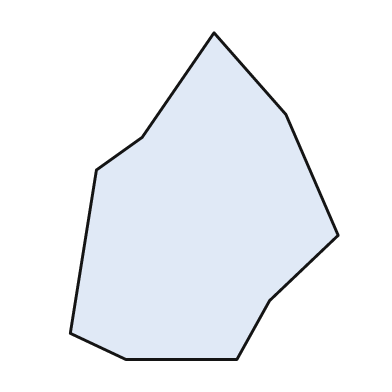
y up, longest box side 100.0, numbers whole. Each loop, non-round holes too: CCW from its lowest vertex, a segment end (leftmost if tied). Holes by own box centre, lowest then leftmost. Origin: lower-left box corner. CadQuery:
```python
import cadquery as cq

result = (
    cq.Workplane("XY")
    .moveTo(17.0, 0.0)
    .lineTo(51.0, 0.0)
    .lineTo(61.0, 18.0)
    .lineTo(82.0, 38.0)
    .lineTo(66.0, 75.0)
    .lineTo(44.0, 100.0)
    .lineTo(22.0, 68.0)
    .lineTo(8.0, 58.0)
    .lineTo(0.0, 8.0)
    .close()
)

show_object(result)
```